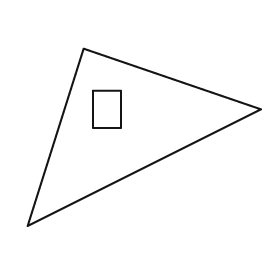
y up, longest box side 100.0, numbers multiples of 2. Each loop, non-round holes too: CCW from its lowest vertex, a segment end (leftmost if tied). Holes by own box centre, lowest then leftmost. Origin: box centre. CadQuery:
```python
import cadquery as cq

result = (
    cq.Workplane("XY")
    .moveTo(-50.0, -38.0)
    .lineTo(50.0, 12.0)
    .lineTo(-26.0, 38.0)
    .close()
    .moveTo(-22.0, 4.0)
    .lineTo(-10.0, 4.0)
    .lineTo(-10.0, 20.0)
    .lineTo(-22.0, 20.0)
    .close()
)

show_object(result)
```